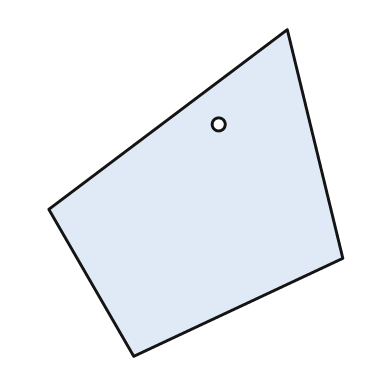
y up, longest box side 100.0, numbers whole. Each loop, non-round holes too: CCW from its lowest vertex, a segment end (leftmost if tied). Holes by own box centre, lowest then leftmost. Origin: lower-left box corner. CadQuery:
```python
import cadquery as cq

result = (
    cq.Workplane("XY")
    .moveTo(26.0, 0.0)
    .lineTo(90.0, 30.0)
    .lineTo(73.0, 100.0)
    .lineTo(0.0, 45.0)
    .close()
    .moveTo(52.0, 71.0)
    .circle(2.0)
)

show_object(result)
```